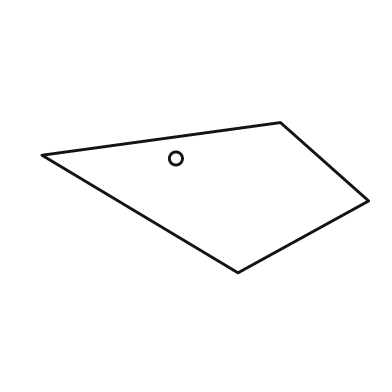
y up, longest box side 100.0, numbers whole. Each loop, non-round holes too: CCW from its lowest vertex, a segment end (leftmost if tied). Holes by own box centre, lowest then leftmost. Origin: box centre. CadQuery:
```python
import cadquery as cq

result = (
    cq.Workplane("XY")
    .moveTo(10.0, -23.0)
    .lineTo(50.0, -1.0)
    .lineTo(23.0, 23.0)
    .lineTo(-50.0, 13.0)
    .close()
    .moveTo(-9.0, 12.0)
    .circle(2.0)
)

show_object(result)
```